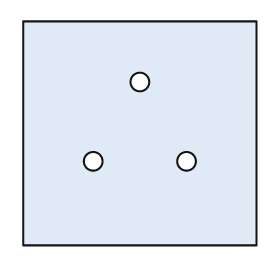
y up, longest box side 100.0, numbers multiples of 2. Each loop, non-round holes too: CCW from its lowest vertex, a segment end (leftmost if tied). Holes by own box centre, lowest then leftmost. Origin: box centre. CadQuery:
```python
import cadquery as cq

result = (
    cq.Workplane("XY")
    .moveTo(-50.0, -48.0)
    .lineTo(50.0, -48.0)
    .lineTo(50.0, 48.0)
    .lineTo(-50.0, 48.0)
    .close()
    .moveTo(-20.0, -12.0)
    .circle(4.0)
    .moveTo(20.0, -12.0)
    .circle(4.0)
    .moveTo(0.0, 22.0)
    .circle(4.0)
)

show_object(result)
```